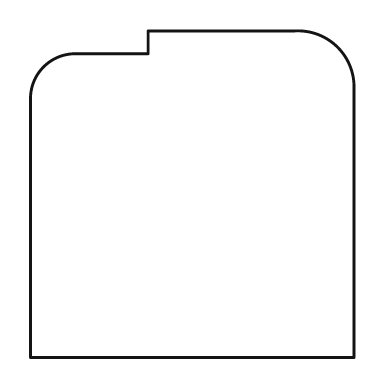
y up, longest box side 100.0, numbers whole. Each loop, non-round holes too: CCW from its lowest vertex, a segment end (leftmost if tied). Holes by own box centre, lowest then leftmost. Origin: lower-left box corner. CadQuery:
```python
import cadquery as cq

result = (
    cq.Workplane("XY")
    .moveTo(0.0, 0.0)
    .lineTo(99.0, 0.0)
    .lineTo(99.0, 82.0)
    .threePointArc((94.0, 95.0), (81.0, 100.0))
    .lineTo(36.0, 100.0)
    .lineTo(36.0, 93.0)
    .lineTo(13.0, 93.0)
    .threePointArc((4.0, 89.0), (0.0, 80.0))
    .close()
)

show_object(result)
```